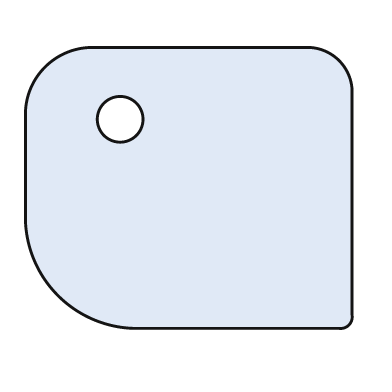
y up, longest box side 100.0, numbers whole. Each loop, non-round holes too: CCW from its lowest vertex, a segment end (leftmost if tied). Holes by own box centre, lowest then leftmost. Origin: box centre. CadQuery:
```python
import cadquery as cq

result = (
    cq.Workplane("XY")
    .moveTo(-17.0, -43.0)
    .lineTo(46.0, -43.0)
    .threePointArc((49.0, -42.0), (50.0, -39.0))
    .lineTo(50.0, 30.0)
    .threePointArc((46.0, 39.0), (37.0, 43.0))
    .lineTo(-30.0, 43.0)
    .threePointArc((-44.0, 37.0), (-50.0, 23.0))
    .lineTo(-50.0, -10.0)
    .threePointArc((-40.0, -33.0), (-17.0, -43.0))
    .close()
    .moveTo(-21.0, 21.0)
    .circle(7.0)
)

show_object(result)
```